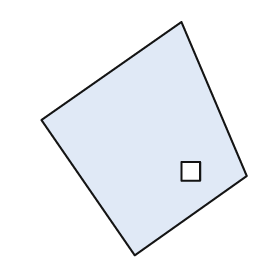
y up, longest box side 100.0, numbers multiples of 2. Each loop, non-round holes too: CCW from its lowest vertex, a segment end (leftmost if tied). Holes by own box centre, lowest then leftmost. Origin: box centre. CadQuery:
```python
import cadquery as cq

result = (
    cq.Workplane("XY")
    .moveTo(-4.0, -50.0)
    .lineTo(44.0, -16.0)
    .lineTo(16.0, 50.0)
    .lineTo(-44.0, 8.0)
    .close()
    .moveTo(16.0, -18.0)
    .lineTo(24.0, -18.0)
    .lineTo(24.0, -10.0)
    .lineTo(16.0, -10.0)
    .close()
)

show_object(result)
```